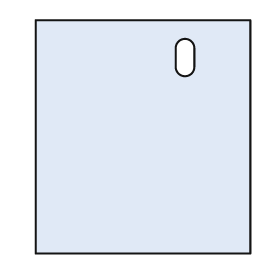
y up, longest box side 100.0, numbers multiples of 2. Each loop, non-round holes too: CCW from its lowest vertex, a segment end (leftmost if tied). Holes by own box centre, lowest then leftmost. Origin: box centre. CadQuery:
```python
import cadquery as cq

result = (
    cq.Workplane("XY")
    .moveTo(-46.0, -50.0)
    .lineTo(46.0, -50.0)
    .lineTo(46.0, 50.0)
    .lineTo(-46.0, 50.0)
    .close()
    .moveTo(14.0, 30.0)
    .threePointArc((18.0, 26.0), (22.0, 30.0))
    .lineTo(22.0, 38.0)
    .threePointArc((18.0, 42.0), (14.0, 38.0))
    .close()
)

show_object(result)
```